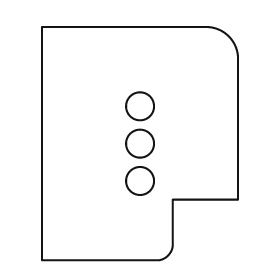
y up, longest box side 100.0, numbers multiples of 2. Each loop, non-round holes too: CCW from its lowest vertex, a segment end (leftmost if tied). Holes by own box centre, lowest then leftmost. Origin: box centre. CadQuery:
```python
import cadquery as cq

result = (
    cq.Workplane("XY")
    .moveTo(-42.0, -50.0)
    .lineTo(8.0, -50.0)
    .threePointArc((12.0, -48.0), (14.0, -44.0))
    .lineTo(14.0, -24.0)
    .lineTo(42.0, -24.0)
    .lineTo(42.0, 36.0)
    .threePointArc((38.0, 46.0), (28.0, 50.0))
    .lineTo(-42.0, 50.0)
    .close()
    .moveTo(0.0, -16.0)
    .circle(6.0)
    .moveTo(0.0, 0.0)
    .circle(6.0)
    .moveTo(0.0, 16.0)
    .circle(6.0)
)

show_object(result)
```